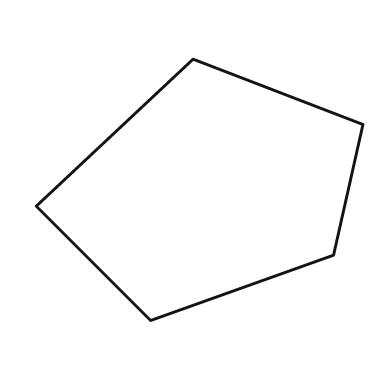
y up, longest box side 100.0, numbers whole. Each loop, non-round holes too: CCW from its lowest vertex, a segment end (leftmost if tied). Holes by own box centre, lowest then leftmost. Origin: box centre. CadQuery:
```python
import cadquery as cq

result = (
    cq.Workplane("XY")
    .moveTo(-15.0, -40.0)
    .lineTo(41.0, -20.0)
    .lineTo(50.0, 20.0)
    .lineTo(-2.0, 40.0)
    .lineTo(-50.0, -5.0)
    .close()
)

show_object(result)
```